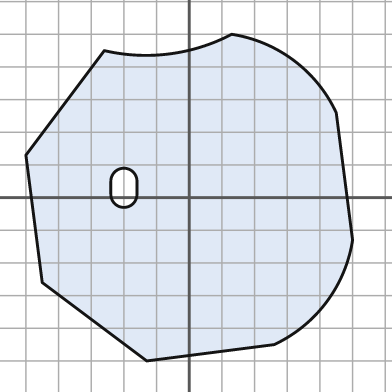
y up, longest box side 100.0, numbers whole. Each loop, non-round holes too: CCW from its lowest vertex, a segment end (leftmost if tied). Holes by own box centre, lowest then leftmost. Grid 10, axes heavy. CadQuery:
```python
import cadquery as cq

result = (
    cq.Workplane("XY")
    .moveTo(-13.0, -50.0)
    .lineTo(26.0, -45.0)
    .threePointArc((42.0, -32.0), (50.0, -13.0))
    .lineTo(45.0, 26.0)
    .threePointArc((32.0, 42.0), (13.0, 50.0))
    .threePointArc((-6.0, 44.0), (-26.0, 45.0))
    .lineTo(-50.0, 13.0)
    .lineTo(-45.0, -26.0)
    .close()
    .moveTo(-24.0, 1.0)
    .threePointArc((-20.0, -3.0), (-16.0, 1.0))
    .lineTo(-16.0, 5.0)
    .threePointArc((-20.0, 9.0), (-24.0, 5.0))
    .close()
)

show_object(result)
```